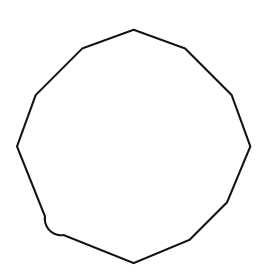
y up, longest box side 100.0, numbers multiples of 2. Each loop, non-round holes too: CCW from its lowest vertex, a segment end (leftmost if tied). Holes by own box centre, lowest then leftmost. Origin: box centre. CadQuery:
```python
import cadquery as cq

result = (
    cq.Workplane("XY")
    .moveTo(0.0, -50.0)
    .lineTo(24.0, -40.0)
    .lineTo(40.0, -24.0)
    .lineTo(50.0, 0.0)
    .lineTo(42.0, 22.0)
    .lineTo(22.0, 42.0)
    .lineTo(0.0, 50.0)
    .lineTo(-22.0, 42.0)
    .lineTo(-42.0, 22.0)
    .lineTo(-50.0, 0.0)
    .lineTo(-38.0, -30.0)
    .threePointArc((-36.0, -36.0), (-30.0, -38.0))
    .close()
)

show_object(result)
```